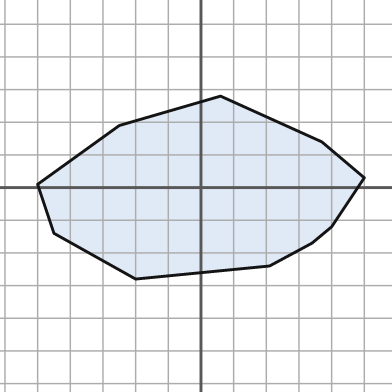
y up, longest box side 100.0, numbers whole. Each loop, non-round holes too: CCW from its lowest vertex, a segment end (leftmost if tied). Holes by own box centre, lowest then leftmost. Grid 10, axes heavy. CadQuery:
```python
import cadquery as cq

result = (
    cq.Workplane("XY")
    .moveTo(-20.0, -28.0)
    .lineTo(21.0, -24.0)
    .lineTo(34.0, -17.0)
    .lineTo(40.0, -12.0)
    .lineTo(50.0, 3.0)
    .lineTo(37.0, 14.0)
    .lineTo(6.0, 28.0)
    .lineTo(-25.0, 19.0)
    .lineTo(-50.0, 1.0)
    .lineTo(-45.0, -14.0)
    .close()
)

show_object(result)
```